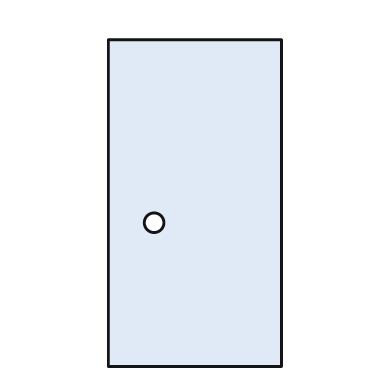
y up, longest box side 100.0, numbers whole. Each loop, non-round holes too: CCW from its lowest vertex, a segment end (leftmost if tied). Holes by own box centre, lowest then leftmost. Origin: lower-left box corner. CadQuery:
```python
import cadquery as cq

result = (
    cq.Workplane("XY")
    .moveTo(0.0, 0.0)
    .lineTo(53.0, 0.0)
    .lineTo(53.0, 100.0)
    .lineTo(0.0, 100.0)
    .close()
    .moveTo(14.0, 44.0)
    .circle(3.0)
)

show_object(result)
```